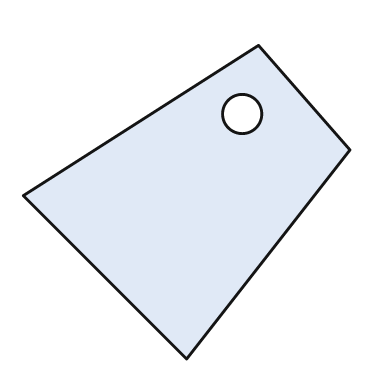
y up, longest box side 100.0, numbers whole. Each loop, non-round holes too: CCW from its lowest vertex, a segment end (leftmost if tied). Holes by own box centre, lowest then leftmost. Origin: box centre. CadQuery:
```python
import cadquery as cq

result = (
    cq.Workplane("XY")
    .moveTo(0.0, -48.0)
    .lineTo(50.0, 16.0)
    .lineTo(22.0, 48.0)
    .lineTo(-50.0, 2.0)
    .close()
    .moveTo(17.0, 27.0)
    .circle(6.0)
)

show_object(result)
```